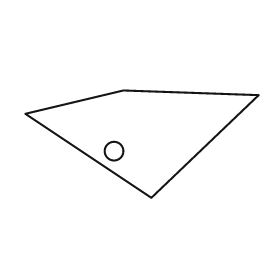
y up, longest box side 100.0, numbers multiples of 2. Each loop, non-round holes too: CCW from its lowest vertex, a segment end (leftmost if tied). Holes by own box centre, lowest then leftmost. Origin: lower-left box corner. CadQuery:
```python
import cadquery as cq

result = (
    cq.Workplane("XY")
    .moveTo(54.0, 0.0)
    .lineTo(100.0, 44.0)
    .lineTo(42.0, 46.0)
    .lineTo(0.0, 36.0)
    .close()
    .moveTo(38.0, 20.0)
    .circle(4.0)
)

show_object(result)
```